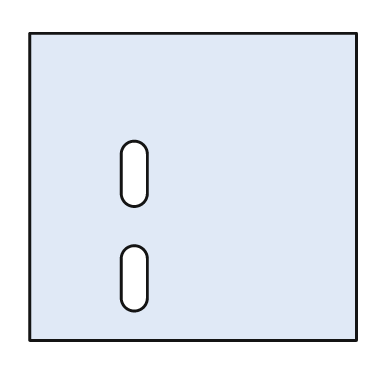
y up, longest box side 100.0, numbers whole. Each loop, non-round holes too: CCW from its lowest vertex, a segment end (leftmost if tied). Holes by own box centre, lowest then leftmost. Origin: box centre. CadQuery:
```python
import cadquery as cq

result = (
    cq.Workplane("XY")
    .moveTo(-50.0, -47.0)
    .lineTo(50.0, -47.0)
    .lineTo(50.0, 47.0)
    .lineTo(-50.0, 47.0)
    .close()
    .moveTo(-22.0, -34.0)
    .threePointArc((-18.0, -38.0), (-14.0, -34.0))
    .lineTo(-14.0, -22.0)
    .threePointArc((-18.0, -18.0), (-22.0, -22.0))
    .close()
    .moveTo(-22.0, -2.0)
    .threePointArc((-18.0, -6.0), (-14.0, -2.0))
    .lineTo(-14.0, 10.0)
    .threePointArc((-18.0, 14.0), (-22.0, 10.0))
    .close()
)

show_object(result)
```